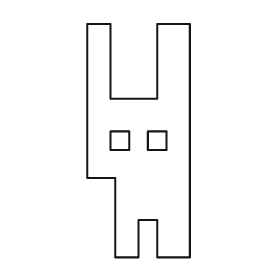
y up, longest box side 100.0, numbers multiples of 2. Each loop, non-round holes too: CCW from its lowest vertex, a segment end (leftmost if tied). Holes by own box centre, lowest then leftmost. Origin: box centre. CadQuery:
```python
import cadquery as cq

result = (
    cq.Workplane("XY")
    .moveTo(-10.0, -50.0)
    .lineTo(0.0, -50.0)
    .lineTo(0.0, -34.0)
    .lineTo(8.0, -34.0)
    .lineTo(8.0, -50.0)
    .lineTo(22.0, -50.0)
    .lineTo(22.0, 50.0)
    .lineTo(8.0, 50.0)
    .lineTo(8.0, 18.0)
    .lineTo(-12.0, 18.0)
    .lineTo(-12.0, 50.0)
    .lineTo(-22.0, 50.0)
    .lineTo(-22.0, -16.0)
    .lineTo(-10.0, -16.0)
    .close()
    .moveTo(-12.0, -4.0)
    .lineTo(-4.0, -4.0)
    .lineTo(-4.0, 4.0)
    .lineTo(-12.0, 4.0)
    .close()
    .moveTo(4.0, -4.0)
    .lineTo(12.0, -4.0)
    .lineTo(12.0, 4.0)
    .lineTo(4.0, 4.0)
    .close()
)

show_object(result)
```